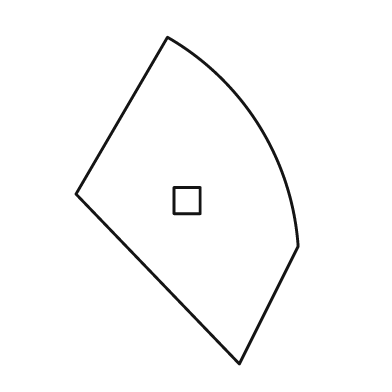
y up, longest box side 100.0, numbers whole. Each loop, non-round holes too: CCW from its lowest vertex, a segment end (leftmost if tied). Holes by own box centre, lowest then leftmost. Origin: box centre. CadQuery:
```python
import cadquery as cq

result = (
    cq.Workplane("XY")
    .moveTo(16.0, -50.0)
    .lineTo(34.0, -14.0)
    .threePointArc((22.0, 23.0), (-6.0, 50.0))
    .lineTo(-34.0, 2.0)
    .close()
    .moveTo(-4.0, -4.0)
    .lineTo(4.0, -4.0)
    .lineTo(4.0, 4.0)
    .lineTo(-4.0, 4.0)
    .close()
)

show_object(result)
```